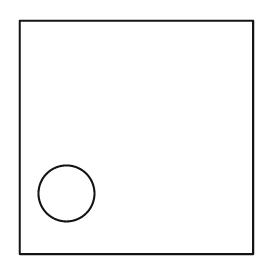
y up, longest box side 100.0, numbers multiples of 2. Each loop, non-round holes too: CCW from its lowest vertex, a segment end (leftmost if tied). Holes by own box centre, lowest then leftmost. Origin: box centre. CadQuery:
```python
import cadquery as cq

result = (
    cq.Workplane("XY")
    .moveTo(-50.0, -50.0)
    .lineTo(50.0, -50.0)
    .lineTo(50.0, 50.0)
    .lineTo(-50.0, 50.0)
    .close()
    .moveTo(-30.0, -24.0)
    .circle(12.0)
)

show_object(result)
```